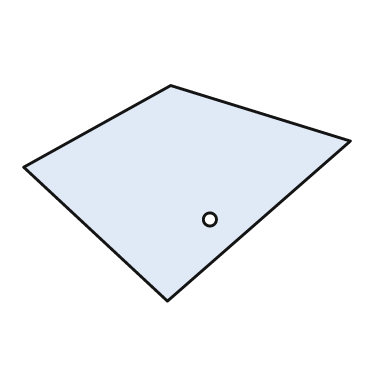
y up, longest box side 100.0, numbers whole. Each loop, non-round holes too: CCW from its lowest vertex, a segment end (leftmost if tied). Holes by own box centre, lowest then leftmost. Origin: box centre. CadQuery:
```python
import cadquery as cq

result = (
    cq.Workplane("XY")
    .moveTo(-6.0, -33.0)
    .lineTo(50.0, 16.0)
    .lineTo(-5.0, 33.0)
    .lineTo(-50.0, 8.0)
    .close()
    .moveTo(7.0, -8.0)
    .circle(2.0)
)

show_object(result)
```